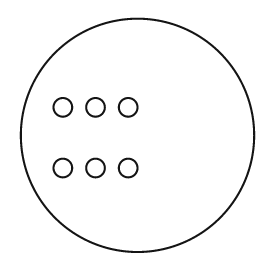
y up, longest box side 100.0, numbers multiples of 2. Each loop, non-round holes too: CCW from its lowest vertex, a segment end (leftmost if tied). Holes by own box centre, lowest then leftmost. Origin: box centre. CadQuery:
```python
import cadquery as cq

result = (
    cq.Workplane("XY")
    .moveTo(0.0, 0.0)
    .circle(50.0)
    .moveTo(-32.0, -14.0)
    .circle(4.0)
    .moveTo(-18.0, -14.0)
    .circle(4.0)
    .moveTo(-4.0, -14.0)
    .circle(4.0)
    .moveTo(-32.0, 12.0)
    .circle(4.0)
    .moveTo(-18.0, 12.0)
    .circle(4.0)
    .moveTo(-4.0, 12.0)
    .circle(4.0)
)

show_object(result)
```